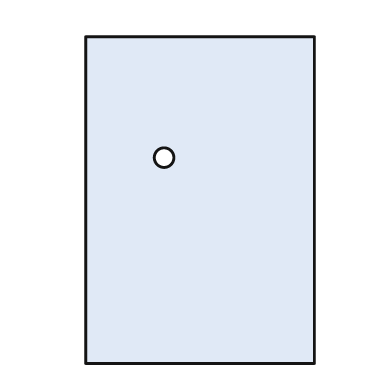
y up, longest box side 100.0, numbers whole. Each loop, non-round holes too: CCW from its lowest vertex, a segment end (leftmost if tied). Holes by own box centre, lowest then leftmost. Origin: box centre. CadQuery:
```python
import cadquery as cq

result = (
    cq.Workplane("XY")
    .moveTo(-35.0, -50.0)
    .lineTo(35.0, -50.0)
    .lineTo(35.0, 50.0)
    .lineTo(-35.0, 50.0)
    .close()
    .moveTo(-11.0, 13.0)
    .circle(3.0)
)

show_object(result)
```